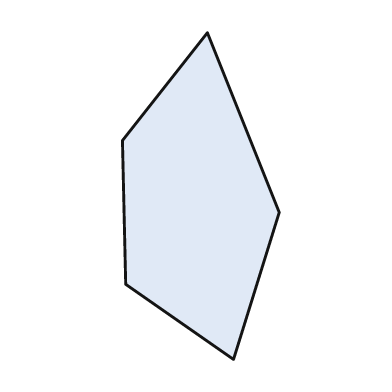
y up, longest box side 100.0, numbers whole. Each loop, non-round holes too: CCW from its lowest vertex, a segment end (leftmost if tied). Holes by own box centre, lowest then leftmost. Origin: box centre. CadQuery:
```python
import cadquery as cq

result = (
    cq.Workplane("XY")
    .moveTo(10.0, -50.0)
    .lineTo(24.0, -5.0)
    .lineTo(2.0, 50.0)
    .lineTo(-24.0, 17.0)
    .lineTo(-23.0, -27.0)
    .close()
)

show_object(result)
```